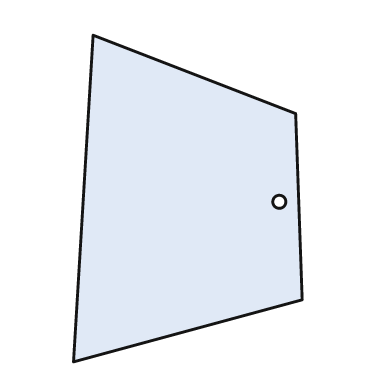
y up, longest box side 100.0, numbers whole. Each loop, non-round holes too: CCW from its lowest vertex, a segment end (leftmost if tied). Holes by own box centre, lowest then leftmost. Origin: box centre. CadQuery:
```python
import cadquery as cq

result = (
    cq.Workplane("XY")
    .moveTo(-35.0, -50.0)
    .lineTo(35.0, -31.0)
    .lineTo(33.0, 26.0)
    .lineTo(-29.0, 50.0)
    .close()
    .moveTo(28.0, -1.0)
    .circle(2.0)
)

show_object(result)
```